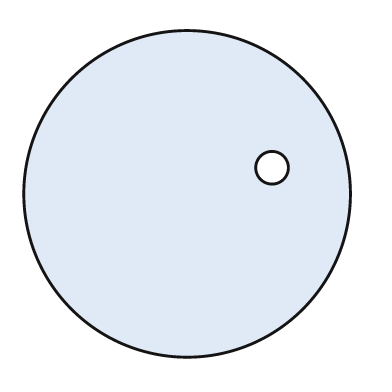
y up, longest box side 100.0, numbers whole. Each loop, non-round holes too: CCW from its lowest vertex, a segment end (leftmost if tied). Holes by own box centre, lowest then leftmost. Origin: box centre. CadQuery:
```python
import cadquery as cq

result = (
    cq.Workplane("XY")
    .moveTo(0.0, 0.0)
    .circle(50.0)
    .moveTo(26.0, 8.0)
    .circle(5.0)
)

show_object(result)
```